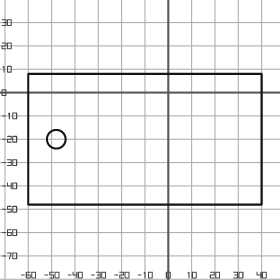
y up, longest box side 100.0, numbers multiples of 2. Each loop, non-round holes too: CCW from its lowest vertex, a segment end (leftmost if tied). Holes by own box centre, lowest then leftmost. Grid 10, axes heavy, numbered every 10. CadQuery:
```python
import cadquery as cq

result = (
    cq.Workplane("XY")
    .moveTo(-60.0, -48.0)
    .lineTo(40.0, -48.0)
    .lineTo(40.0, 8.0)
    .lineTo(-60.0, 8.0)
    .close()
    .moveTo(-48.0, -20.0)
    .circle(4.0)
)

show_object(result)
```